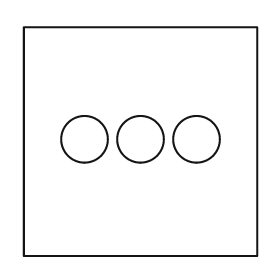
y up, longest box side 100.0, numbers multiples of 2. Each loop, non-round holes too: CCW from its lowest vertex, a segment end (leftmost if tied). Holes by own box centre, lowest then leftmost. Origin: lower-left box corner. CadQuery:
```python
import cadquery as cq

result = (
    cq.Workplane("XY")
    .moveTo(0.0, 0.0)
    .lineTo(100.0, 0.0)
    .lineTo(100.0, 98.0)
    .lineTo(0.0, 98.0)
    .close()
    .moveTo(26.0, 50.0)
    .circle(10.0)
    .moveTo(50.0, 50.0)
    .circle(10.0)
    .moveTo(74.0, 50.0)
    .circle(10.0)
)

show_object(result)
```